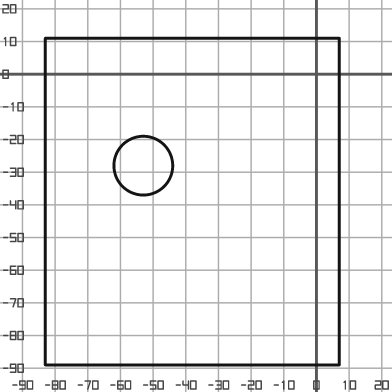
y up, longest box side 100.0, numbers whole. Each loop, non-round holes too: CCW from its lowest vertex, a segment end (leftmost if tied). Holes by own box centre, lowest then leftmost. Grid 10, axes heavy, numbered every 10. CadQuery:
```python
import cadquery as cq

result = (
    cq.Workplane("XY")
    .moveTo(-83.0, -89.0)
    .lineTo(7.0, -89.0)
    .lineTo(7.0, 11.0)
    .lineTo(-83.0, 11.0)
    .close()
    .moveTo(-53.0, -28.0)
    .circle(9.0)
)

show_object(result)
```